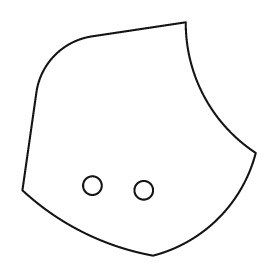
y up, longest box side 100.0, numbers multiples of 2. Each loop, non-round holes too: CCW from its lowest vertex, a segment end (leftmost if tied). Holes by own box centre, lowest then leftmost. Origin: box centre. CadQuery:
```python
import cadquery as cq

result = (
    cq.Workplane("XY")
    .moveTo(6.0, -50.0)
    .threePointArc((34.0, -34.0), (50.0, -6.0))
    .threePointArc((28.0, 18.0), (20.0, 50.0))
    .lineTo(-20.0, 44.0)
    .threePointArc((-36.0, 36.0), (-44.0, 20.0))
    .lineTo(-50.0, -22.0)
    .threePointArc((-24.0, -40.0), (6.0, -50.0))
    .close()
    .moveTo(2.0, -22.0)
    .circle(4.0)
    .moveTo(-20.0, -20.0)
    .circle(4.0)
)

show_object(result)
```